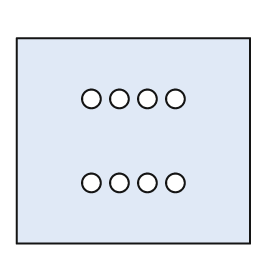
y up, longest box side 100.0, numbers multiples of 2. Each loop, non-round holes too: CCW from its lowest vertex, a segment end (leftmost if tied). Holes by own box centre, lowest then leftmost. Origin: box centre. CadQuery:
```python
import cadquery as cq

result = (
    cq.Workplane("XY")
    .moveTo(-50.0, -44.0)
    .lineTo(50.0, -44.0)
    .lineTo(50.0, 44.0)
    .lineTo(-50.0, 44.0)
    .close()
    .moveTo(-18.0, -18.0)
    .circle(4.0)
    .moveTo(-6.0, -18.0)
    .circle(4.0)
    .moveTo(6.0, -18.0)
    .circle(4.0)
    .moveTo(18.0, -18.0)
    .circle(4.0)
    .moveTo(-18.0, 18.0)
    .circle(4.0)
    .moveTo(-6.0, 18.0)
    .circle(4.0)
    .moveTo(6.0, 18.0)
    .circle(4.0)
    .moveTo(18.0, 18.0)
    .circle(4.0)
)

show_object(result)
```